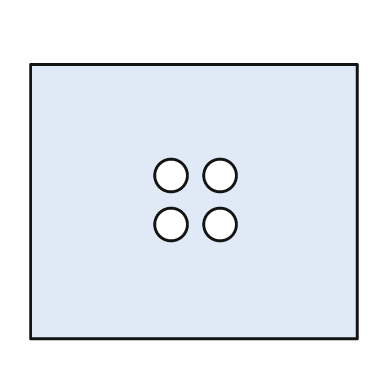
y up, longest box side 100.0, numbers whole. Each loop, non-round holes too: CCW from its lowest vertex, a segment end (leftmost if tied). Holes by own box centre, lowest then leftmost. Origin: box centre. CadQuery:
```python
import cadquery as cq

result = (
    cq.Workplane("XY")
    .moveTo(-50.0, -42.0)
    .lineTo(50.0, -42.0)
    .lineTo(50.0, 42.0)
    .lineTo(-50.0, 42.0)
    .close()
    .moveTo(-7.0, -7.0)
    .circle(5.0)
    .moveTo(8.0, -7.0)
    .circle(5.0)
    .moveTo(-7.0, 8.0)
    .circle(5.0)
    .moveTo(8.0, 8.0)
    .circle(5.0)
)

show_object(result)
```